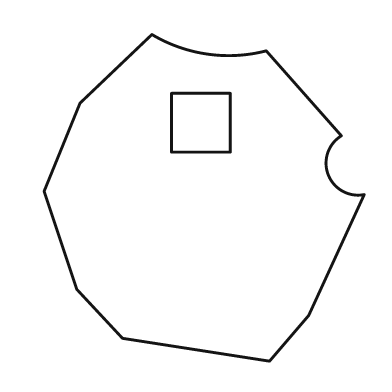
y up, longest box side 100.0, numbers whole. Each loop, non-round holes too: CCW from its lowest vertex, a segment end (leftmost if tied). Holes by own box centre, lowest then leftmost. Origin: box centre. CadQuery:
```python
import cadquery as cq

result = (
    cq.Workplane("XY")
    .moveTo(20.0, -50.0)
    .lineTo(32.0, -36.0)
    .lineTo(49.0, 1.0)
    .threePointArc((38.0, 7.0), (42.0, 19.0))
    .lineTo(19.0, 45.0)
    .threePointArc((1.0, 44.0), (-16.0, 50.0))
    .lineTo(-38.0, 29.0)
    .lineTo(-49.0, 2.0)
    .lineTo(-39.0, -28.0)
    .lineTo(-25.0, -43.0)
    .close()
    .moveTo(-10.0, 14.0)
    .lineTo(8.0, 14.0)
    .lineTo(8.0, 32.0)
    .lineTo(-10.0, 32.0)
    .close()
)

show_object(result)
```